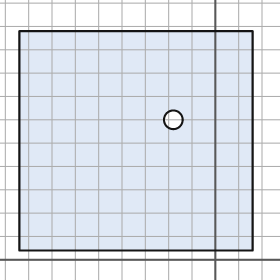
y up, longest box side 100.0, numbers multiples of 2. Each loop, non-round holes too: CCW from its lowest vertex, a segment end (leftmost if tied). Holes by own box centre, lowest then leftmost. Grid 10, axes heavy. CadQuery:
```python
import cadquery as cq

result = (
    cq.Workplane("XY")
    .moveTo(-84.0, 4.0)
    .lineTo(16.0, 4.0)
    .lineTo(16.0, 98.0)
    .lineTo(-84.0, 98.0)
    .close()
    .moveTo(-18.0, 60.0)
    .circle(4.0)
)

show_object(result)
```